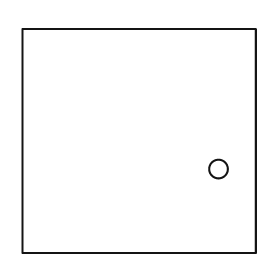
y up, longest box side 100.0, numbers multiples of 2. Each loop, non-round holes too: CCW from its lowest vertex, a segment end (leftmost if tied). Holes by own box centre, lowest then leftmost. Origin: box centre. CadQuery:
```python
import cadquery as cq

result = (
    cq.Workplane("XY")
    .moveTo(-50.0, -48.0)
    .lineTo(50.0, -48.0)
    .lineTo(50.0, 48.0)
    .lineTo(-50.0, 48.0)
    .close()
    .moveTo(34.0, -12.0)
    .circle(4.0)
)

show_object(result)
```